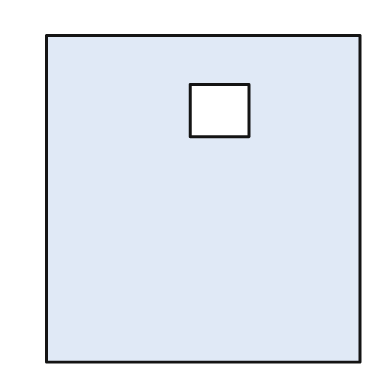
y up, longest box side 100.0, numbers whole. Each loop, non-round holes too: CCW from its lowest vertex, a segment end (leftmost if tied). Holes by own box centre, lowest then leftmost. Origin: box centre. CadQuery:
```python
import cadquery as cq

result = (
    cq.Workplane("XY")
    .moveTo(-48.0, -50.0)
    .lineTo(48.0, -50.0)
    .lineTo(48.0, 50.0)
    .lineTo(-48.0, 50.0)
    .close()
    .moveTo(-4.0, 19.0)
    .lineTo(14.0, 19.0)
    .lineTo(14.0, 35.0)
    .lineTo(-4.0, 35.0)
    .close()
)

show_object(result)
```